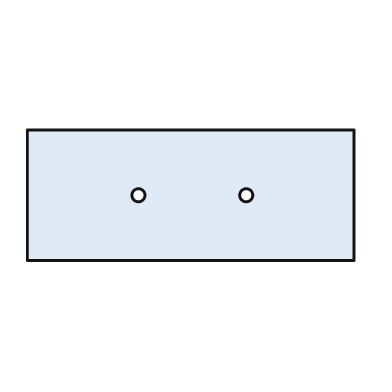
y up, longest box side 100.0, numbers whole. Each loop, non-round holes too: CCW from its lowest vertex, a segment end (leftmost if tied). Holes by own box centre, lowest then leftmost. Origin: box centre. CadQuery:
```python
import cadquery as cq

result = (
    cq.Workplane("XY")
    .moveTo(-50.0, -20.0)
    .lineTo(50.0, -20.0)
    .lineTo(50.0, 20.0)
    .lineTo(-50.0, 20.0)
    .close()
    .moveTo(-16.0, 0.0)
    .circle(2.0)
    .moveTo(17.0, 0.0)
    .circle(2.0)
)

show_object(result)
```